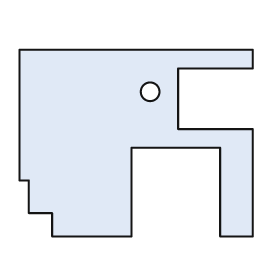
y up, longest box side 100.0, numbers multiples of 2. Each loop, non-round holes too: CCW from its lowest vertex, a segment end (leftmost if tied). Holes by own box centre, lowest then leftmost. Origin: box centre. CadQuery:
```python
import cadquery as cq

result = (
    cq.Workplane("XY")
    .moveTo(-36.0, -40.0)
    .lineTo(-2.0, -40.0)
    .lineTo(-2.0, -2.0)
    .lineTo(36.0, -2.0)
    .lineTo(36.0, -40.0)
    .lineTo(50.0, -40.0)
    .lineTo(50.0, 6.0)
    .lineTo(18.0, 6.0)
    .lineTo(18.0, 32.0)
    .lineTo(50.0, 32.0)
    .lineTo(50.0, 40.0)
    .lineTo(-50.0, 40.0)
    .lineTo(-50.0, -16.0)
    .lineTo(-46.0, -16.0)
    .lineTo(-46.0, -30.0)
    .lineTo(-36.0, -30.0)
    .close()
    .moveTo(6.0, 22.0)
    .circle(4.0)
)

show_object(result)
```